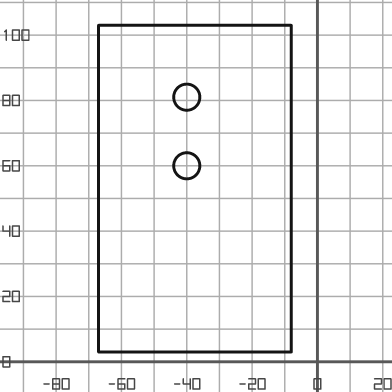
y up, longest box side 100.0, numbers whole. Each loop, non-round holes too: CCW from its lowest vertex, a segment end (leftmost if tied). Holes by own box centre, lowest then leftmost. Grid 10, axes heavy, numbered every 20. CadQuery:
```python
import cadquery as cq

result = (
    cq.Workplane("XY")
    .moveTo(-67.0, 3.0)
    .lineTo(-8.0, 3.0)
    .lineTo(-8.0, 103.0)
    .lineTo(-67.0, 103.0)
    .close()
    .moveTo(-40.0, 60.0)
    .circle(4.0)
    .moveTo(-40.0, 81.0)
    .circle(4.0)
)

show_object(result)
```